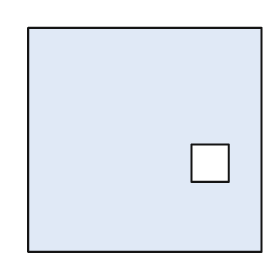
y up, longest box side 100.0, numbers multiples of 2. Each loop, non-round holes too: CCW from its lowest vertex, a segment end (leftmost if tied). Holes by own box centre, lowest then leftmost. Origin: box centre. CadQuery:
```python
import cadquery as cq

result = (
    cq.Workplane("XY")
    .moveTo(-50.0, -48.0)
    .lineTo(50.0, -48.0)
    .lineTo(50.0, 48.0)
    .lineTo(-50.0, 48.0)
    .close()
    .moveTo(20.0, -18.0)
    .lineTo(36.0, -18.0)
    .lineTo(36.0, -2.0)
    .lineTo(20.0, -2.0)
    .close()
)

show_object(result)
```